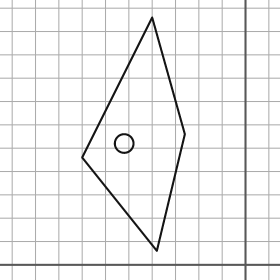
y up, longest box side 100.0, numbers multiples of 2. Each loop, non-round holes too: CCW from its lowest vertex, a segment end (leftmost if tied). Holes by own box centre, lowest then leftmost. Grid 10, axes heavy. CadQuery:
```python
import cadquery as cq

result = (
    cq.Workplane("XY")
    .moveTo(-38.0, 6.0)
    .lineTo(-26.0, 56.0)
    .lineTo(-40.0, 106.0)
    .lineTo(-70.0, 46.0)
    .close()
    .moveTo(-52.0, 52.0)
    .circle(4.0)
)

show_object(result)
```